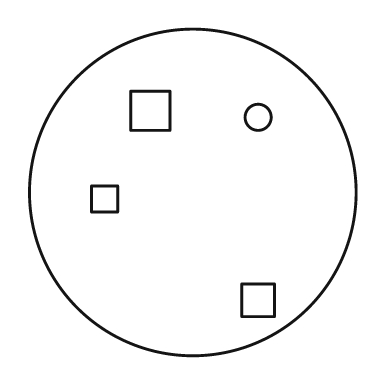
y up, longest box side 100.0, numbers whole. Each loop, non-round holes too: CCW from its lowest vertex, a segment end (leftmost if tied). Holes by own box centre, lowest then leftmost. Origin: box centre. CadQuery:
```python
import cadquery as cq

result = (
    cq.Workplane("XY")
    .moveTo(0.0, 0.0)
    .circle(50.0)
    .moveTo(15.0, -38.0)
    .lineTo(25.0, -38.0)
    .lineTo(25.0, -28.0)
    .lineTo(15.0, -28.0)
    .close()
    .moveTo(-31.0, -6.0)
    .lineTo(-23.0, -6.0)
    .lineTo(-23.0, 2.0)
    .lineTo(-31.0, 2.0)
    .close()
    .moveTo(20.0, 23.0)
    .circle(4.0)
    .moveTo(-19.0, 19.0)
    .lineTo(-7.0, 19.0)
    .lineTo(-7.0, 31.0)
    .lineTo(-19.0, 31.0)
    .close()
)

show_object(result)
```